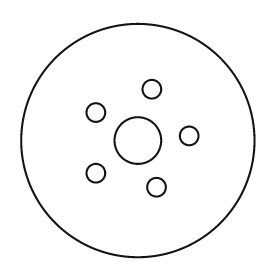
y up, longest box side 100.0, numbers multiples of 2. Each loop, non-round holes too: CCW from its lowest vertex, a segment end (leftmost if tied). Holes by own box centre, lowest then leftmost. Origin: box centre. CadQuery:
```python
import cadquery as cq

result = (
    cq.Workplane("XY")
    .moveTo(0.0, 0.0)
    .circle(50.0)
    .moveTo(8.0, -20.0)
    .circle(4.0)
    .moveTo(-18.0, -14.0)
    .circle(4.0)
    .moveTo(0.0, 0.0)
    .circle(10.0)
    .moveTo(22.0, 2.0)
    .circle(4.0)
    .moveTo(-18.0, 12.0)
    .circle(4.0)
    .moveTo(6.0, 22.0)
    .circle(4.0)
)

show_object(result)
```